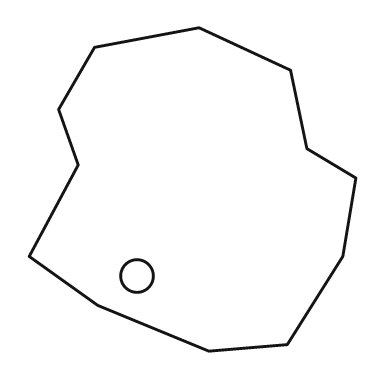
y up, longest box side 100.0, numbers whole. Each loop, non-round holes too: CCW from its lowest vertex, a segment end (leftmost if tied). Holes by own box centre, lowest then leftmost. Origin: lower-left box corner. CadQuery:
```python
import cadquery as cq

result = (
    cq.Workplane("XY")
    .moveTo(55.0, 0.0)
    .lineTo(79.0, 2.0)
    .lineTo(96.0, 29.0)
    .lineTo(100.0, 53.0)
    .lineTo(85.0, 62.0)
    .lineTo(80.0, 86.0)
    .lineTo(52.0, 99.0)
    .lineTo(20.0, 93.0)
    .lineTo(9.0, 74.0)
    .lineTo(15.0, 57.0)
    .lineTo(0.0, 29.0)
    .lineTo(21.0, 14.0)
    .close()
    .moveTo(33.0, 23.0)
    .circle(5.0)
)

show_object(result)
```